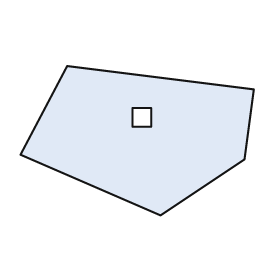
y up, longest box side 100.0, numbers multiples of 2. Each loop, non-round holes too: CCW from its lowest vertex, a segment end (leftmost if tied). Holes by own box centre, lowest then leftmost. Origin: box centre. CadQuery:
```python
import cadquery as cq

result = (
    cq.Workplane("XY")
    .moveTo(10.0, -32.0)
    .lineTo(46.0, -8.0)
    .lineTo(50.0, 22.0)
    .lineTo(-30.0, 32.0)
    .lineTo(-50.0, -6.0)
    .close()
    .moveTo(-2.0, 6.0)
    .lineTo(6.0, 6.0)
    .lineTo(6.0, 14.0)
    .lineTo(-2.0, 14.0)
    .close()
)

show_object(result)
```